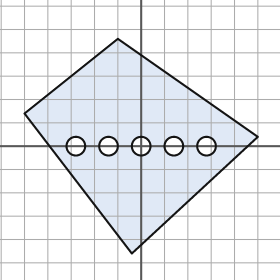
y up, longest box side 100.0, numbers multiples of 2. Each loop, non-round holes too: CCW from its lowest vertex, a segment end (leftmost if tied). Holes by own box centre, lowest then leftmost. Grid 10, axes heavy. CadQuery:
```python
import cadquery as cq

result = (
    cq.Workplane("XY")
    .moveTo(-4.0, -46.0)
    .lineTo(50.0, 4.0)
    .lineTo(-10.0, 46.0)
    .lineTo(-50.0, 14.0)
    .close()
    .moveTo(-28.0, 0.0)
    .circle(4.0)
    .moveTo(-14.0, 0.0)
    .circle(4.0)
    .moveTo(0.0, 0.0)
    .circle(4.0)
    .moveTo(14.0, 0.0)
    .circle(4.0)
    .moveTo(28.0, 0.0)
    .circle(4.0)
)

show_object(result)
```